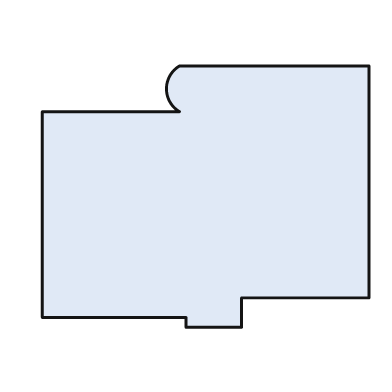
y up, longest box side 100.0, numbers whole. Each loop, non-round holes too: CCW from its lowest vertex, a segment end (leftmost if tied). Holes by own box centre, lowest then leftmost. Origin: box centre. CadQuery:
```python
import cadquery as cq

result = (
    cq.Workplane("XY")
    .moveTo(-6.0, -40.0)
    .lineTo(11.0, -40.0)
    .lineTo(11.0, -31.0)
    .lineTo(50.0, -31.0)
    .lineTo(50.0, 40.0)
    .lineTo(-8.0, 40.0)
    .threePointArc((-12.0, 33.0), (-8.0, 26.0))
    .lineTo(-50.0, 26.0)
    .lineTo(-50.0, -37.0)
    .lineTo(-6.0, -37.0)
    .close()
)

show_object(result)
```